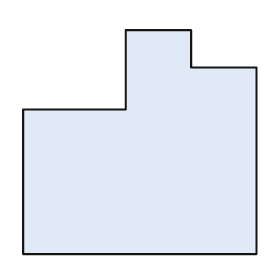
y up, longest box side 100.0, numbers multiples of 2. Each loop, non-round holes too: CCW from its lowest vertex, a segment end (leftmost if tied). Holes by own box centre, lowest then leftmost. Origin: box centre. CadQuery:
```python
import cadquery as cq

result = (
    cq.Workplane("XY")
    .moveTo(-50.0, -48.0)
    .lineTo(50.0, -48.0)
    .lineTo(50.0, 32.0)
    .lineTo(22.0, 32.0)
    .lineTo(22.0, 48.0)
    .lineTo(-6.0, 48.0)
    .lineTo(-6.0, 14.0)
    .lineTo(-50.0, 14.0)
    .close()
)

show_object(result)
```